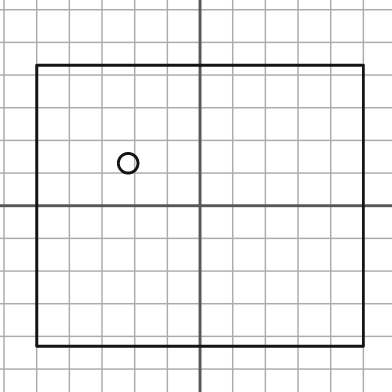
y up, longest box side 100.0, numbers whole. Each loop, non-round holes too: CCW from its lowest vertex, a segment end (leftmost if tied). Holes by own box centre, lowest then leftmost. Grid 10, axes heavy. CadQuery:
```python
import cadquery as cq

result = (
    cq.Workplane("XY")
    .moveTo(-50.0, -43.0)
    .lineTo(50.0, -43.0)
    .lineTo(50.0, 43.0)
    .lineTo(-50.0, 43.0)
    .close()
    .moveTo(-22.0, 13.0)
    .circle(3.0)
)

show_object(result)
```